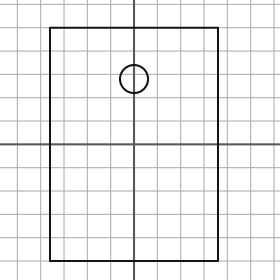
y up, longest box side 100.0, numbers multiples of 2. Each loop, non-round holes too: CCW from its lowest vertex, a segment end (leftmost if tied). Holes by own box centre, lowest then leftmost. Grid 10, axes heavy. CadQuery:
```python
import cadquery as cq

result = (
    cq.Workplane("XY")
    .moveTo(-36.0, -50.0)
    .lineTo(36.0, -50.0)
    .lineTo(36.0, 50.0)
    .lineTo(-36.0, 50.0)
    .close()
    .moveTo(0.0, 28.0)
    .circle(6.0)
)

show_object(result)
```